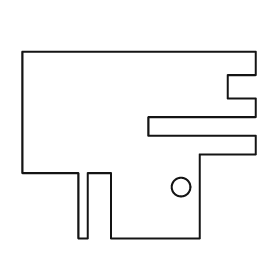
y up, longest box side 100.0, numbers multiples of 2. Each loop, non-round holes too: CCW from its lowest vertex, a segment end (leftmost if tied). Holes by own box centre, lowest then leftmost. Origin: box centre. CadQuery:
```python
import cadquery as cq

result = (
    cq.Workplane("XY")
    .moveTo(-26.0, -40.0)
    .lineTo(-22.0, -40.0)
    .lineTo(-22.0, -12.0)
    .lineTo(-12.0, -12.0)
    .lineTo(-12.0, -40.0)
    .lineTo(26.0, -40.0)
    .lineTo(26.0, -4.0)
    .lineTo(50.0, -4.0)
    .lineTo(50.0, 4.0)
    .lineTo(4.0, 4.0)
    .lineTo(4.0, 12.0)
    .lineTo(50.0, 12.0)
    .lineTo(50.0, 20.0)
    .lineTo(38.0, 20.0)
    .lineTo(38.0, 30.0)
    .lineTo(50.0, 30.0)
    .lineTo(50.0, 40.0)
    .lineTo(-50.0, 40.0)
    .lineTo(-50.0, -12.0)
    .lineTo(-26.0, -12.0)
    .close()
    .moveTo(18.0, -18.0)
    .circle(4.0)
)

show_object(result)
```